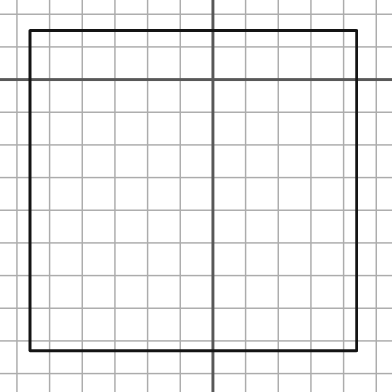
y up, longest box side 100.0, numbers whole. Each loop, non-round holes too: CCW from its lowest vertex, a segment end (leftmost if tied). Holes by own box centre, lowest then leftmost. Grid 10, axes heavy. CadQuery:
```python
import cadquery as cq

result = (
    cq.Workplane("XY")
    .moveTo(-56.0, -83.0)
    .lineTo(44.0, -83.0)
    .lineTo(44.0, 15.0)
    .lineTo(-56.0, 15.0)
    .close()
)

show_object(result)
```